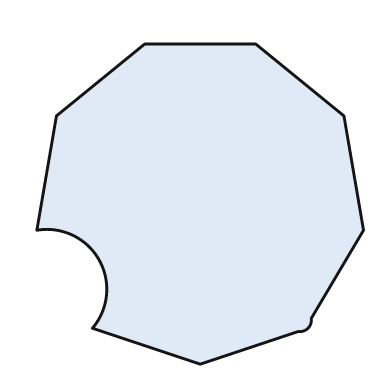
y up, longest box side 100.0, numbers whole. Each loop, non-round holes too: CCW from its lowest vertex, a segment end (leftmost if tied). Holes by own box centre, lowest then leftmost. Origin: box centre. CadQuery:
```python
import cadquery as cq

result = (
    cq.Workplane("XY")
    .moveTo(0.0, -49.0)
    .lineTo(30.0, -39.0)
    .threePointArc((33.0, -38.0), (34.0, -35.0))
    .lineTo(50.0, -8.0)
    .lineTo(44.0, 27.0)
    .lineTo(17.0, 49.0)
    .lineTo(-17.0, 49.0)
    .lineTo(-44.0, 27.0)
    .lineTo(-50.0, -8.0)
    .threePointArc((-31.0, -17.0), (-33.0, -38.0))
    .close()
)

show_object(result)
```